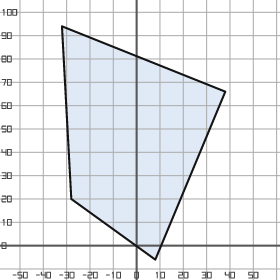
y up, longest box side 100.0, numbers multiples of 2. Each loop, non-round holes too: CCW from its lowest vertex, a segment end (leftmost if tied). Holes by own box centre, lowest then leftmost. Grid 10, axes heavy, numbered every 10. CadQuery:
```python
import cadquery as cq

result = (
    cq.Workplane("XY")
    .moveTo(8.0, -6.0)
    .lineTo(38.0, 66.0)
    .lineTo(-32.0, 94.0)
    .lineTo(-28.0, 20.0)
    .close()
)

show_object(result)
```